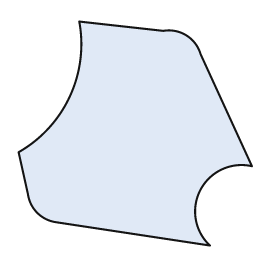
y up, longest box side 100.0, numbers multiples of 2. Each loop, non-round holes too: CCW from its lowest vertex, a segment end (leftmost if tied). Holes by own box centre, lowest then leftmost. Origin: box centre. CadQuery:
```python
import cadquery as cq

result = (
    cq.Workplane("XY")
    .moveTo(32.0, -48.0)
    .threePointArc((28.0, -24.0), (50.0, -14.0))
    .lineTo(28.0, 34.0)
    .threePointArc((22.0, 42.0), (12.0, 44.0))
    .lineTo(-24.0, 48.0)
    .threePointArc((-28.0, 16.0), (-50.0, -8.0))
    .lineTo(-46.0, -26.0)
    .threePointArc((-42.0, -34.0), (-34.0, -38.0))
    .close()
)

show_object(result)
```